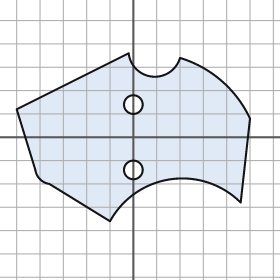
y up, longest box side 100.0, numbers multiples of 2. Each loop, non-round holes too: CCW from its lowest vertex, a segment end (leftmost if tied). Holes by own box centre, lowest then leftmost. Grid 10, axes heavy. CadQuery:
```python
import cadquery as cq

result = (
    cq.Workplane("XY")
    .moveTo(-10.0, -36.0)
    .threePointArc((16.0, -18.0), (46.0, -28.0))
    .lineTo(50.0, 8.0)
    .threePointArc((38.0, 24.0), (20.0, 34.0))
    .threePointArc((8.0, 26.0), (-2.0, 36.0))
    .lineTo(-50.0, 12.0)
    .lineTo(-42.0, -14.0)
    .threePointArc((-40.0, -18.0), (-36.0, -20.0))
    .close()
    .moveTo(0.0, -14.0)
    .circle(4.0)
    .moveTo(0.0, 14.0)
    .circle(4.0)
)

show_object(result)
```